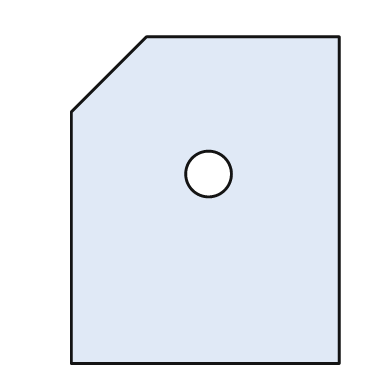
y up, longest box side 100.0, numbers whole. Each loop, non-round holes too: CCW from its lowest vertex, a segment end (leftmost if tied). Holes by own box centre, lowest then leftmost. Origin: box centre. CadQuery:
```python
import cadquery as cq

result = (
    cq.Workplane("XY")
    .moveTo(-41.0, -50.0)
    .lineTo(41.0, -50.0)
    .lineTo(41.0, 50.0)
    .lineTo(-18.0, 50.0)
    .lineTo(-41.0, 27.0)
    .close()
    .moveTo(1.0, 8.0)
    .circle(7.0)
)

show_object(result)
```